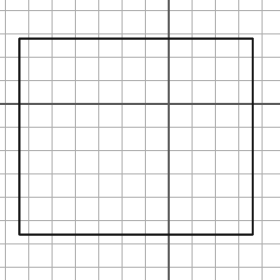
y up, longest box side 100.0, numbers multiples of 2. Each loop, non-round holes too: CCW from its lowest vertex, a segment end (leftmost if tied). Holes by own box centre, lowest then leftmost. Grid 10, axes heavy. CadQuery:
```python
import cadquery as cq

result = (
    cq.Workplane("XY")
    .moveTo(-64.0, -56.0)
    .lineTo(36.0, -56.0)
    .lineTo(36.0, 28.0)
    .lineTo(-64.0, 28.0)
    .close()
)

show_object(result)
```